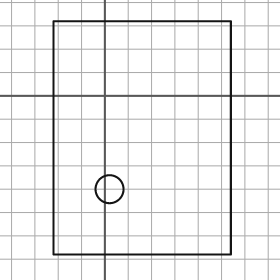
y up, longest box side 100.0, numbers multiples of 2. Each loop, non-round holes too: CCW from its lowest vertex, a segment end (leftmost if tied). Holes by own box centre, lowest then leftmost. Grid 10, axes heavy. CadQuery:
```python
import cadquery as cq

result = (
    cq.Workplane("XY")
    .moveTo(-22.0, -68.0)
    .lineTo(54.0, -68.0)
    .lineTo(54.0, 32.0)
    .lineTo(-22.0, 32.0)
    .close()
    .moveTo(2.0, -40.0)
    .circle(6.0)
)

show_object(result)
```